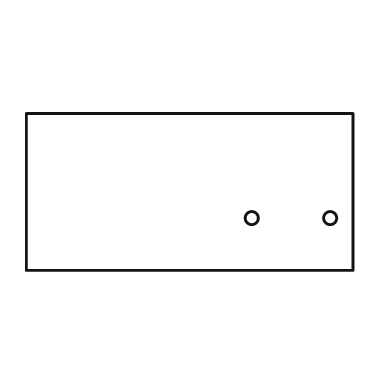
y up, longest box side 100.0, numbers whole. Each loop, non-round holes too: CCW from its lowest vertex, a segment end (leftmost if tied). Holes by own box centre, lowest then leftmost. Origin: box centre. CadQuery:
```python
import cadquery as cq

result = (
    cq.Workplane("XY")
    .moveTo(-50.0, -24.0)
    .lineTo(50.0, -24.0)
    .lineTo(50.0, 24.0)
    .lineTo(-50.0, 24.0)
    .close()
    .moveTo(19.0, -8.0)
    .circle(2.0)
    .moveTo(43.0, -8.0)
    .circle(2.0)
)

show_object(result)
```